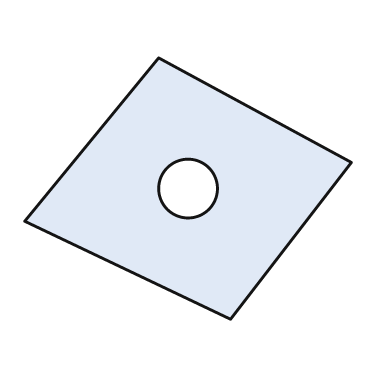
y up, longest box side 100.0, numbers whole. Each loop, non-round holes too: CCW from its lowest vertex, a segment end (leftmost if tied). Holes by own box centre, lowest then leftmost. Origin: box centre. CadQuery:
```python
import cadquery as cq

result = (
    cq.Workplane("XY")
    .moveTo(13.0, -40.0)
    .lineTo(50.0, 8.0)
    .lineTo(-9.0, 40.0)
    .lineTo(-50.0, -10.0)
    .close()
    .moveTo(0.0, 0.0)
    .circle(9.0)
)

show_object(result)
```